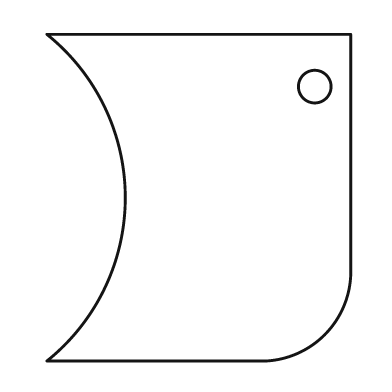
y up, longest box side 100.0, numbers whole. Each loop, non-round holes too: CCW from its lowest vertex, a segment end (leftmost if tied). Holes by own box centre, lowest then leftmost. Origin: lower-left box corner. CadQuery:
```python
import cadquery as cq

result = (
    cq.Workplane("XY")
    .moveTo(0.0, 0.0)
    .lineTo(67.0, 0.0)
    .threePointArc((85.0, 8.0), (93.0, 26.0))
    .lineTo(93.0, 100.0)
    .lineTo(0.0, 100.0)
    .threePointArc((24.0, 50.0), (0.0, 0.0))
    .close()
    .moveTo(82.0, 84.0)
    .circle(5.0)
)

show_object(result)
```